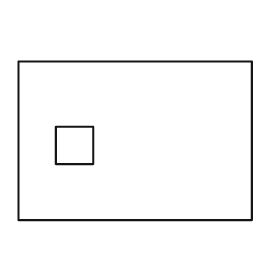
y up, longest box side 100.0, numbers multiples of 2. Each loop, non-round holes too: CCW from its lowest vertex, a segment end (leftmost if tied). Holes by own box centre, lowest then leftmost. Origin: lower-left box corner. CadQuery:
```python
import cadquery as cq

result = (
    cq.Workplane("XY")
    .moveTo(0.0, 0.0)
    .lineTo(100.0, 0.0)
    .lineTo(100.0, 68.0)
    .lineTo(0.0, 68.0)
    .close()
    .moveTo(16.0, 24.0)
    .lineTo(32.0, 24.0)
    .lineTo(32.0, 40.0)
    .lineTo(16.0, 40.0)
    .close()
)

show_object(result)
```